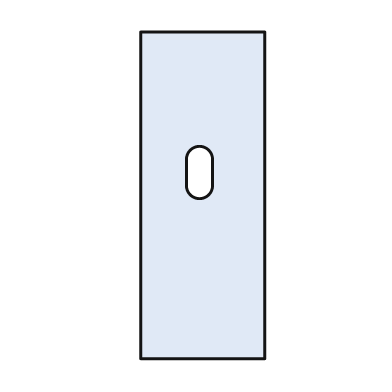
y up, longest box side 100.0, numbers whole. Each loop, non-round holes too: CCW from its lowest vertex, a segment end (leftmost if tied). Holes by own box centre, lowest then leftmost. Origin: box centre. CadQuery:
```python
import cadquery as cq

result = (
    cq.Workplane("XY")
    .moveTo(-19.0, -50.0)
    .lineTo(19.0, -50.0)
    .lineTo(19.0, 50.0)
    .lineTo(-19.0, 50.0)
    .close()
    .moveTo(-5.0, 3.0)
    .threePointArc((-1.0, -1.0), (3.0, 3.0))
    .lineTo(3.0, 11.0)
    .threePointArc((-1.0, 15.0), (-5.0, 11.0))
    .close()
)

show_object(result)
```